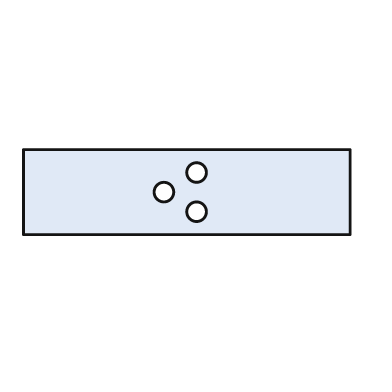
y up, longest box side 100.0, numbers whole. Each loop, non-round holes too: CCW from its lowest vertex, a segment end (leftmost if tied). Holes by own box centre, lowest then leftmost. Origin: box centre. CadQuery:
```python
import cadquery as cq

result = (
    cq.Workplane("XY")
    .moveTo(-50.0, -13.0)
    .lineTo(50.0, -13.0)
    .lineTo(50.0, 13.0)
    .lineTo(-50.0, 13.0)
    .close()
    .moveTo(3.0, -6.0)
    .circle(3.0)
    .moveTo(-7.0, 0.0)
    .circle(3.0)
    .moveTo(3.0, 6.0)
    .circle(3.0)
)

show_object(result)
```